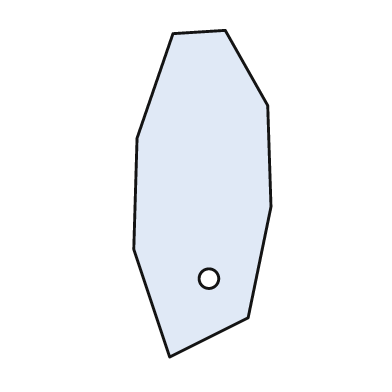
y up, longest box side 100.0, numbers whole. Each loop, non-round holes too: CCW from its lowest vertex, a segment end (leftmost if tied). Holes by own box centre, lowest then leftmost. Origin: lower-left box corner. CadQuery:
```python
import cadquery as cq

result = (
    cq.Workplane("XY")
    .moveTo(11.0, 0.0)
    .lineTo(35.0, 12.0)
    .lineTo(42.0, 46.0)
    .lineTo(41.0, 77.0)
    .lineTo(28.0, 100.0)
    .lineTo(12.0, 99.0)
    .lineTo(1.0, 67.0)
    .lineTo(0.0, 33.0)
    .close()
    .moveTo(23.0, 24.0)
    .circle(3.0)
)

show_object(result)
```